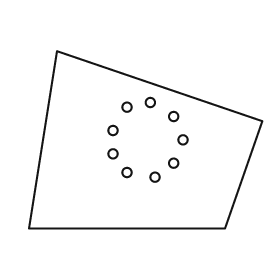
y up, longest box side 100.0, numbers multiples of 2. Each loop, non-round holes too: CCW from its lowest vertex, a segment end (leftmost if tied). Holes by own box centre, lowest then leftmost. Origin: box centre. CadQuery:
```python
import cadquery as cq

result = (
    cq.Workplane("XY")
    .moveTo(-50.0, -38.0)
    .lineTo(34.0, -38.0)
    .lineTo(50.0, 8.0)
    .lineTo(-38.0, 38.0)
    .close()
    .moveTo(4.0, -16.0)
    .circle(2.0)
    .moveTo(-8.0, -14.0)
    .circle(2.0)
    .moveTo(12.0, -10.0)
    .circle(2.0)
    .moveTo(-14.0, -6.0)
    .circle(2.0)
    .moveTo(16.0, 0.0)
    .circle(2.0)
    .moveTo(-14.0, 4.0)
    .circle(2.0)
    .moveTo(12.0, 10.0)
    .circle(2.0)
    .moveTo(-8.0, 14.0)
    .circle(2.0)
    .moveTo(2.0, 16.0)
    .circle(2.0)
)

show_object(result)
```